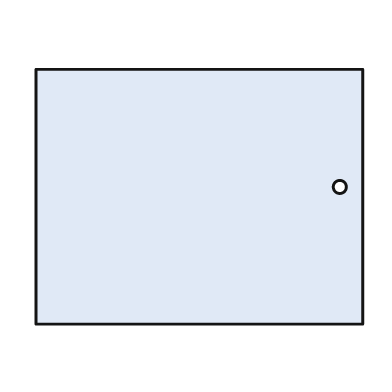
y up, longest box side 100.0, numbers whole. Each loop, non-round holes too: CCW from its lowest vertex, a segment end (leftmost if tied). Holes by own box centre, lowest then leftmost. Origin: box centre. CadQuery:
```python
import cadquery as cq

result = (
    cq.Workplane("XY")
    .moveTo(-50.0, -39.0)
    .lineTo(50.0, -39.0)
    .lineTo(50.0, 39.0)
    .lineTo(-50.0, 39.0)
    .close()
    .moveTo(43.0, 3.0)
    .circle(2.0)
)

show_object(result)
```